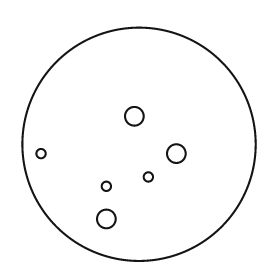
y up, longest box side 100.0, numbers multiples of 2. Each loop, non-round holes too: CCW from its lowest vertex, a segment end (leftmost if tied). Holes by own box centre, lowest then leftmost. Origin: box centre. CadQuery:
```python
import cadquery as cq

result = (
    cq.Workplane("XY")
    .moveTo(0.0, 0.0)
    .circle(50.0)
    .moveTo(-14.0, -32.0)
    .circle(4.0)
    .moveTo(-14.0, -18.0)
    .circle(2.0)
    .moveTo(4.0, -14.0)
    .circle(2.0)
    .moveTo(-42.0, -4.0)
    .circle(2.0)
    .moveTo(16.0, -4.0)
    .circle(4.0)
    .moveTo(-2.0, 12.0)
    .circle(4.0)
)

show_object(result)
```